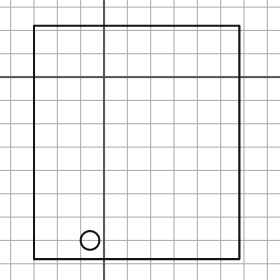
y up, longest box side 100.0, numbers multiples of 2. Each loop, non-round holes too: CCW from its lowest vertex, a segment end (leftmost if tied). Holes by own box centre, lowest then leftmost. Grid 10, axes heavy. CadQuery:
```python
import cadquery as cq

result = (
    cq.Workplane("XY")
    .moveTo(-30.0, -78.0)
    .lineTo(58.0, -78.0)
    .lineTo(58.0, 22.0)
    .lineTo(-30.0, 22.0)
    .close()
    .moveTo(-6.0, -70.0)
    .circle(4.0)
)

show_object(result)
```